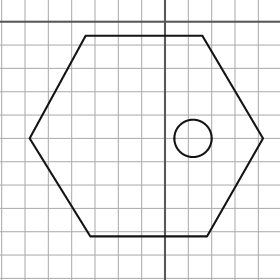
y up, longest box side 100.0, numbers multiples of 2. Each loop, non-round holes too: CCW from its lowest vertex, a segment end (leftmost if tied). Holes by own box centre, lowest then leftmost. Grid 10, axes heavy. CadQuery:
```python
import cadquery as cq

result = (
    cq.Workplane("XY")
    .moveTo(-32.0, -92.0)
    .lineTo(18.0, -92.0)
    .lineTo(42.0, -50.0)
    .lineTo(16.0, -6.0)
    .lineTo(-34.0, -6.0)
    .lineTo(-58.0, -50.0)
    .close()
    .moveTo(12.0, -50.0)
    .circle(8.0)
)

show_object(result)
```